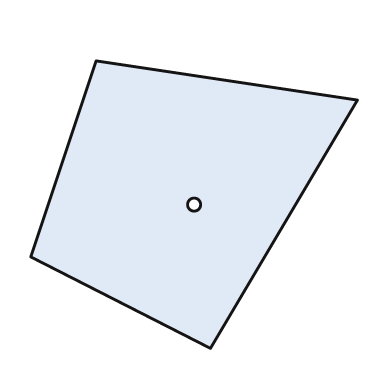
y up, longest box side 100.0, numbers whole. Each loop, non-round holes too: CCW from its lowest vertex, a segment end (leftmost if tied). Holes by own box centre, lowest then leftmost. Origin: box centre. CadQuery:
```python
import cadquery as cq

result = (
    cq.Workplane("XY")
    .moveTo(5.0, -44.0)
    .lineTo(50.0, 32.0)
    .lineTo(-30.0, 44.0)
    .lineTo(-50.0, -16.0)
    .close()
    .moveTo(0.0, 0.0)
    .circle(2.0)
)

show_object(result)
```